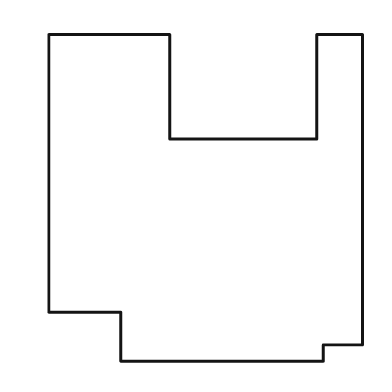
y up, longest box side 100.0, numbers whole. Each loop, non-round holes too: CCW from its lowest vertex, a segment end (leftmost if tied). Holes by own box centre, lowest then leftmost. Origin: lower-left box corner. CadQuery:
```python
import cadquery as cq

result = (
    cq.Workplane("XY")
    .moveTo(22.0, 0.0)
    .lineTo(84.0, 0.0)
    .lineTo(84.0, 5.0)
    .lineTo(96.0, 5.0)
    .lineTo(96.0, 100.0)
    .lineTo(82.0, 100.0)
    .lineTo(82.0, 68.0)
    .lineTo(37.0, 68.0)
    .lineTo(37.0, 100.0)
    .lineTo(0.0, 100.0)
    .lineTo(0.0, 15.0)
    .lineTo(22.0, 15.0)
    .close()
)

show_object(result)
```